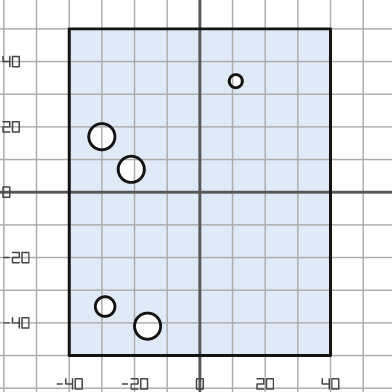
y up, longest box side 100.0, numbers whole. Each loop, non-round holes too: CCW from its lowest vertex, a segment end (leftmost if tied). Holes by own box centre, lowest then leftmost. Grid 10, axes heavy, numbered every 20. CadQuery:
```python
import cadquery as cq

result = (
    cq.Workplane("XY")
    .moveTo(-40.0, -50.0)
    .lineTo(40.0, -50.0)
    .lineTo(40.0, 50.0)
    .lineTo(-40.0, 50.0)
    .close()
    .moveTo(-16.0, -41.0)
    .circle(4.0)
    .moveTo(-29.0, -35.0)
    .circle(3.0)
    .moveTo(-21.0, 7.0)
    .circle(4.0)
    .moveTo(-30.0, 17.0)
    .circle(4.0)
    .moveTo(11.0, 34.0)
    .circle(2.0)
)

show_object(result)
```